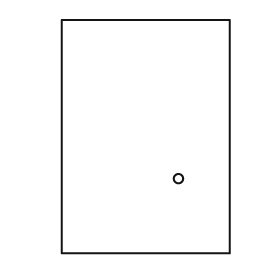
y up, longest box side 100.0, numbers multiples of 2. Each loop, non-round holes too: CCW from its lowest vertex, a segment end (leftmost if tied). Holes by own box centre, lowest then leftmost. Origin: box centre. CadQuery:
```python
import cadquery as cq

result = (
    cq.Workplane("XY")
    .moveTo(-36.0, -50.0)
    .lineTo(36.0, -50.0)
    .lineTo(36.0, 50.0)
    .lineTo(-36.0, 50.0)
    .close()
    .moveTo(14.0, -18.0)
    .circle(2.0)
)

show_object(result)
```